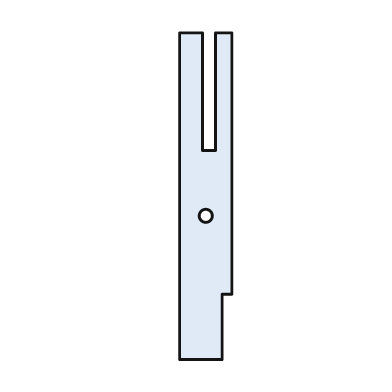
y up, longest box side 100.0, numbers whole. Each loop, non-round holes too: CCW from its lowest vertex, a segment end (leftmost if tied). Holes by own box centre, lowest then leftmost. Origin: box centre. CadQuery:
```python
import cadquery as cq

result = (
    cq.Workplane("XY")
    .moveTo(-8.0, -50.0)
    .lineTo(5.0, -50.0)
    .lineTo(5.0, -30.0)
    .lineTo(8.0, -30.0)
    .lineTo(8.0, 50.0)
    .lineTo(3.0, 50.0)
    .lineTo(3.0, 14.0)
    .lineTo(-1.0, 14.0)
    .lineTo(-1.0, 50.0)
    .lineTo(-8.0, 50.0)
    .close()
    .moveTo(0.0, -6.0)
    .circle(2.0)
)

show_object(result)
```